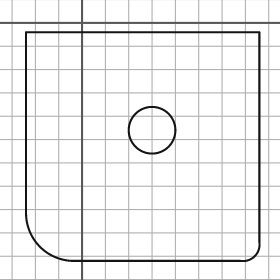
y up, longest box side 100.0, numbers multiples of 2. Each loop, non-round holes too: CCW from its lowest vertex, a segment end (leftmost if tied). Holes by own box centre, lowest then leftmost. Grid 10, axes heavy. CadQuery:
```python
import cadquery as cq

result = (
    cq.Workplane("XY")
    .moveTo(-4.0, -102.0)
    .lineTo(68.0, -102.0)
    .threePointArc((74.0, -100.0), (76.0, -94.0))
    .lineTo(76.0, -4.0)
    .lineTo(-24.0, -4.0)
    .lineTo(-24.0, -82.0)
    .threePointArc((-18.0, -96.0), (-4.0, -102.0))
    .close()
    .moveTo(30.0, -46.0)
    .circle(10.0)
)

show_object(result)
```